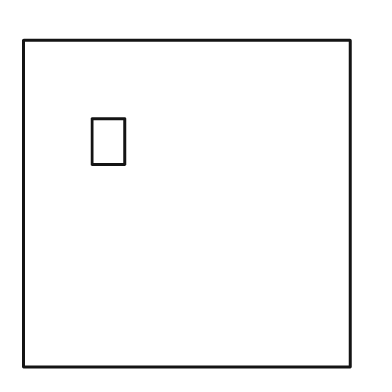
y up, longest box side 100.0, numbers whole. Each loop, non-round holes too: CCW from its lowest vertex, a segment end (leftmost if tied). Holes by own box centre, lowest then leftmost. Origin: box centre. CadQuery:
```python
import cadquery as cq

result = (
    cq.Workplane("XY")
    .moveTo(-50.0, -50.0)
    .lineTo(50.0, -50.0)
    .lineTo(50.0, 50.0)
    .lineTo(-50.0, 50.0)
    .close()
    .moveTo(-29.0, 12.0)
    .lineTo(-19.0, 12.0)
    .lineTo(-19.0, 26.0)
    .lineTo(-29.0, 26.0)
    .close()
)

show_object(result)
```